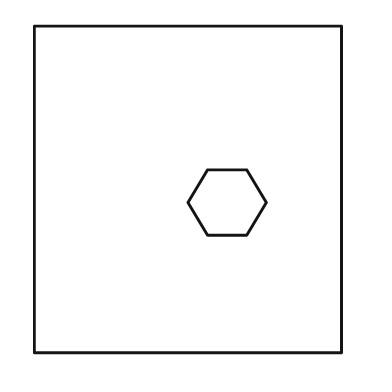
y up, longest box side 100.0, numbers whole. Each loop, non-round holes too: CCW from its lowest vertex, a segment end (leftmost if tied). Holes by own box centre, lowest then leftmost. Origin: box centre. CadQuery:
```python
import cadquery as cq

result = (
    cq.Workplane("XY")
    .moveTo(-47.0, -50.0)
    .lineTo(47.0, -50.0)
    .lineTo(47.0, 50.0)
    .lineTo(-47.0, 50.0)
    .close()
    .moveTo(6.0, -14.0)
    .lineTo(18.0, -14.0)
    .lineTo(24.0, -4.0)
    .lineTo(18.0, 6.0)
    .lineTo(6.0, 6.0)
    .lineTo(0.0, -4.0)
    .close()
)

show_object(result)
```